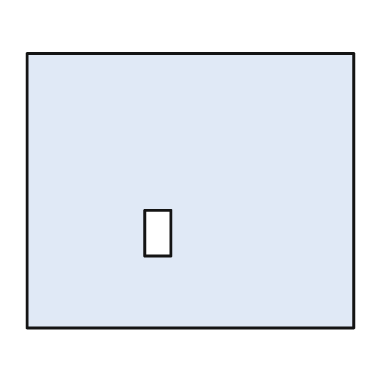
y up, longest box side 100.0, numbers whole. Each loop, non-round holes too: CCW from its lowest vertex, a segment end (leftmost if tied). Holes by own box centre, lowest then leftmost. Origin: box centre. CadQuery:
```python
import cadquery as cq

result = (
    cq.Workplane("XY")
    .moveTo(-50.0, -42.0)
    .lineTo(50.0, -42.0)
    .lineTo(50.0, 42.0)
    .lineTo(-50.0, 42.0)
    .close()
    .moveTo(-14.0, -20.0)
    .lineTo(-6.0, -20.0)
    .lineTo(-6.0, -6.0)
    .lineTo(-14.0, -6.0)
    .close()
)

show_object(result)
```